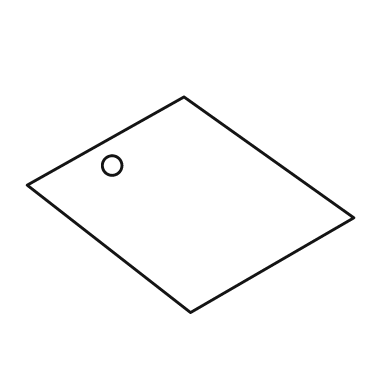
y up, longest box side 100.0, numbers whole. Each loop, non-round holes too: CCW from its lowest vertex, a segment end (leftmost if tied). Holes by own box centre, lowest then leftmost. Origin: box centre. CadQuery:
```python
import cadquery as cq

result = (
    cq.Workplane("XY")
    .moveTo(0.0, -33.0)
    .lineTo(50.0, -4.0)
    .lineTo(-2.0, 33.0)
    .lineTo(-50.0, 6.0)
    .close()
    .moveTo(-24.0, 12.0)
    .circle(3.0)
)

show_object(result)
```